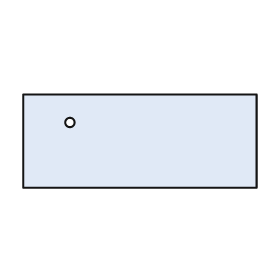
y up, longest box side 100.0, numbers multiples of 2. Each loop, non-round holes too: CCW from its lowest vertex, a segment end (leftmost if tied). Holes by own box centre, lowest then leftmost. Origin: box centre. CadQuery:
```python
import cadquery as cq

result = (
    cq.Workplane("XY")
    .moveTo(-50.0, -20.0)
    .lineTo(50.0, -20.0)
    .lineTo(50.0, 20.0)
    .lineTo(-50.0, 20.0)
    .close()
    .moveTo(-30.0, 8.0)
    .circle(2.0)
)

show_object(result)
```